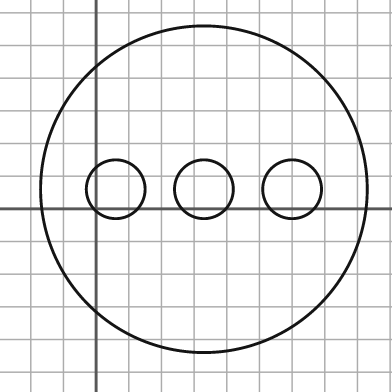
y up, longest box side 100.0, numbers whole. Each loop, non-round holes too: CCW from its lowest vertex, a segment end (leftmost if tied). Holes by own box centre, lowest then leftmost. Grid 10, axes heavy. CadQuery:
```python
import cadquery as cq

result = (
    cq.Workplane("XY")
    .moveTo(33.0, 6.0)
    .circle(50.0)
    .moveTo(6.0, 6.0)
    .circle(9.0)
    .moveTo(33.0, 6.0)
    .circle(9.0)
    .moveTo(60.0, 6.0)
    .circle(9.0)
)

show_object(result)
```